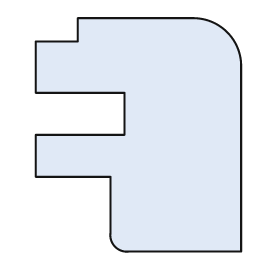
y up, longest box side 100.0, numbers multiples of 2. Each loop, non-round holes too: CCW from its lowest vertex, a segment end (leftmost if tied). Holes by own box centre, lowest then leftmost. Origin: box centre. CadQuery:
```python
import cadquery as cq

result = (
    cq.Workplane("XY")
    .moveTo(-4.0, -50.0)
    .lineTo(44.0, -50.0)
    .lineTo(44.0, 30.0)
    .threePointArc((38.0, 44.0), (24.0, 50.0))
    .lineTo(-26.0, 50.0)
    .lineTo(-26.0, 40.0)
    .lineTo(-44.0, 40.0)
    .lineTo(-44.0, 18.0)
    .lineTo(-6.0, 18.0)
    .lineTo(-6.0, 0.0)
    .lineTo(-44.0, 0.0)
    .lineTo(-44.0, -18.0)
    .lineTo(-12.0, -18.0)
    .lineTo(-12.0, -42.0)
    .threePointArc((-10.0, -48.0), (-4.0, -50.0))
    .close()
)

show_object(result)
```